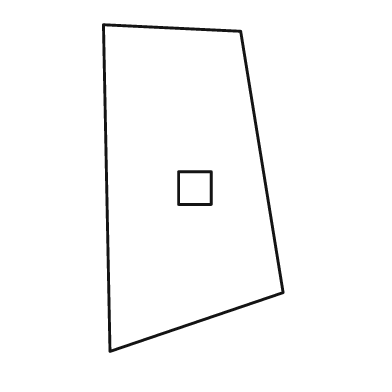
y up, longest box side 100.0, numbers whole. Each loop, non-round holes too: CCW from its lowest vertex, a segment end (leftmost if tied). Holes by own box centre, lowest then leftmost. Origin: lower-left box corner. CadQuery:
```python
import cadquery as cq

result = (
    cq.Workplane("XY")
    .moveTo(2.0, 0.0)
    .lineTo(55.0, 18.0)
    .lineTo(42.0, 98.0)
    .lineTo(0.0, 100.0)
    .close()
    .moveTo(23.0, 45.0)
    .lineTo(33.0, 45.0)
    .lineTo(33.0, 55.0)
    .lineTo(23.0, 55.0)
    .close()
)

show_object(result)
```